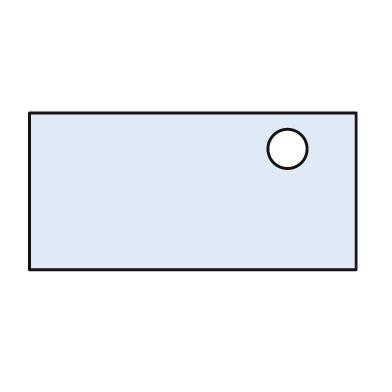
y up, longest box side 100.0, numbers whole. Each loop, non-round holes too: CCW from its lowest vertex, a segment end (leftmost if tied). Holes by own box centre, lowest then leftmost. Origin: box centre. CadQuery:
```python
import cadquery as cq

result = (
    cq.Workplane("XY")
    .moveTo(-50.0, -24.0)
    .lineTo(50.0, -24.0)
    .lineTo(50.0, 24.0)
    .lineTo(-50.0, 24.0)
    .close()
    .moveTo(29.0, 13.0)
    .circle(6.0)
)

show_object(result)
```